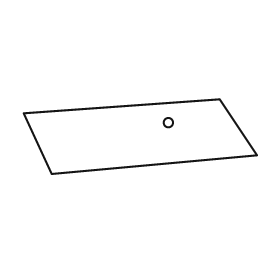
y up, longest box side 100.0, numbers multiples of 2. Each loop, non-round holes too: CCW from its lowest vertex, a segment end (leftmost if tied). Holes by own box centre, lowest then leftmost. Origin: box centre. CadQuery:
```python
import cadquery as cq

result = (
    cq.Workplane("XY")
    .moveTo(-38.0, -16.0)
    .lineTo(50.0, -8.0)
    .lineTo(34.0, 16.0)
    .lineTo(-50.0, 10.0)
    .close()
    .moveTo(12.0, 6.0)
    .circle(2.0)
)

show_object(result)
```